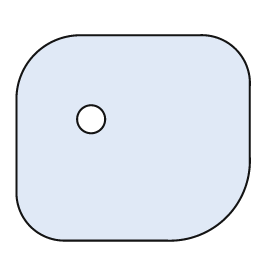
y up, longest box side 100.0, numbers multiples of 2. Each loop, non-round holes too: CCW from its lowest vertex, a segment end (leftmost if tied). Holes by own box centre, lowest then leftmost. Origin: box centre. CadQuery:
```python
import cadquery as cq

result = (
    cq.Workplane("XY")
    .moveTo(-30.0, -44.0)
    .lineTo(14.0, -44.0)
    .threePointArc((40.0, -34.0), (50.0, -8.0))
    .lineTo(50.0, 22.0)
    .threePointArc((44.0, 38.0), (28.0, 44.0))
    .lineTo(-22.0, 44.0)
    .threePointArc((-42.0, 36.0), (-50.0, 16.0))
    .lineTo(-50.0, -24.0)
    .threePointArc((-44.0, -38.0), (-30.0, -44.0))
    .close()
    .moveTo(-18.0, 8.0)
    .circle(6.0)
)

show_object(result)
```